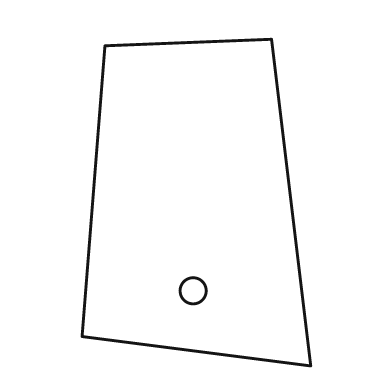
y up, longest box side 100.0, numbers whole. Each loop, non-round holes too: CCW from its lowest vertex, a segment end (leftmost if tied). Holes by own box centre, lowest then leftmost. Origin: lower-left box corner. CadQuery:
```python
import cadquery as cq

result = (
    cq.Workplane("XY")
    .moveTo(70.0, 0.0)
    .lineTo(58.0, 100.0)
    .lineTo(7.0, 98.0)
    .lineTo(0.0, 9.0)
    .close()
    .moveTo(34.0, 23.0)
    .circle(4.0)
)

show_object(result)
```